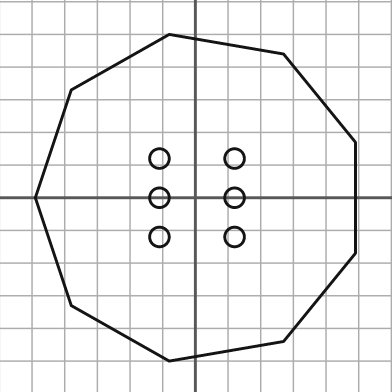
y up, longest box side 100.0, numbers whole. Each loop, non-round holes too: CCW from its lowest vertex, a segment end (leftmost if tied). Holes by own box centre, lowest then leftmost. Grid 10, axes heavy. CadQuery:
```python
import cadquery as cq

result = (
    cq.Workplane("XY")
    .moveTo(-8.0, -50.0)
    .lineTo(27.0, -44.0)
    .lineTo(49.0, -17.0)
    .lineTo(49.0, 17.0)
    .lineTo(27.0, 44.0)
    .lineTo(-8.0, 50.0)
    .lineTo(-38.0, 33.0)
    .lineTo(-49.0, 0.0)
    .lineTo(-38.0, -33.0)
    .close()
    .moveTo(-11.0, -12.0)
    .circle(3.0)
    .moveTo(12.0, -12.0)
    .circle(3.0)
    .moveTo(-11.0, 0.0)
    .circle(3.0)
    .moveTo(12.0, 0.0)
    .circle(3.0)
    .moveTo(-11.0, 12.0)
    .circle(3.0)
    .moveTo(12.0, 12.0)
    .circle(3.0)
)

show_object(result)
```